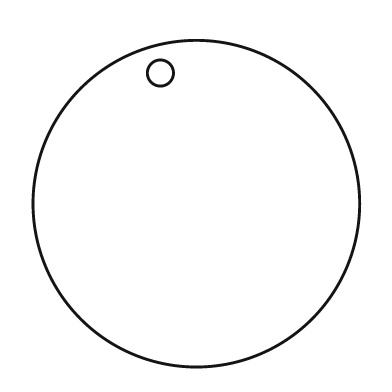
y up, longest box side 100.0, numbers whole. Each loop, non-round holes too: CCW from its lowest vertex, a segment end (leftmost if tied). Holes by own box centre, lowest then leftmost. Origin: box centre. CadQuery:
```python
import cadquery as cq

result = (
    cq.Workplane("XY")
    .moveTo(0.0, 0.0)
    .circle(50.0)
    .moveTo(-11.0, 40.0)
    .circle(4.0)
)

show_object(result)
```